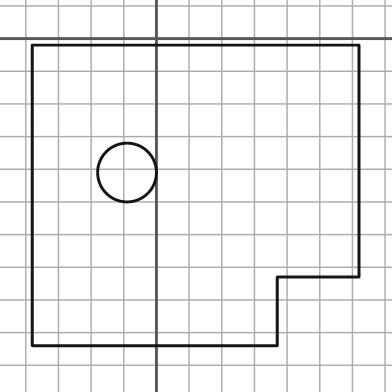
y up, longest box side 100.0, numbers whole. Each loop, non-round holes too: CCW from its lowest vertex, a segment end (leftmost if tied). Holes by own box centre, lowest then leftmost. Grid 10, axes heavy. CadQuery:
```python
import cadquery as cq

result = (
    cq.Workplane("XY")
    .moveTo(-38.0, -94.0)
    .lineTo(37.0, -94.0)
    .lineTo(37.0, -73.0)
    .lineTo(62.0, -73.0)
    .lineTo(62.0, -2.0)
    .lineTo(-38.0, -2.0)
    .close()
    .moveTo(-9.0, -41.0)
    .circle(9.0)
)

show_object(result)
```